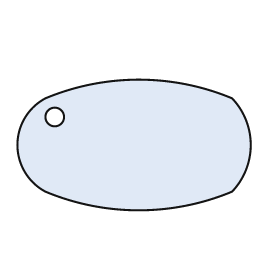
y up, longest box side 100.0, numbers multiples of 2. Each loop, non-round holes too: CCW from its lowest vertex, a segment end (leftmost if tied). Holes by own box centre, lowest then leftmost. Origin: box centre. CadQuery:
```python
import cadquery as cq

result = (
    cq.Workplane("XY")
    .moveTo(-38.0, -20.0)
    .threePointArc((2.0, -28.0), (42.0, -20.0))
    .threePointArc((50.0, 0.0), (42.0, 20.0))
    .threePointArc((2.0, 28.0), (-38.0, 20.0))
    .threePointArc((-50.0, 0.0), (-38.0, -20.0))
    .close()
    .moveTo(-34.0, 12.0)
    .circle(4.0)
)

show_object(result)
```